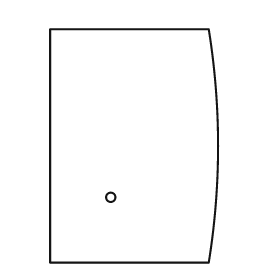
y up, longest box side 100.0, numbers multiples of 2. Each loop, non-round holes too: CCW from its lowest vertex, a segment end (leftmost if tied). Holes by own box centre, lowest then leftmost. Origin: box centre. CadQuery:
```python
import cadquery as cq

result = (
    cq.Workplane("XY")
    .moveTo(-36.0, -50.0)
    .lineTo(32.0, -50.0)
    .threePointArc((36.0, 0.0), (32.0, 50.0))
    .lineTo(-36.0, 50.0)
    .close()
    .moveTo(-10.0, -22.0)
    .circle(2.0)
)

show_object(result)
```